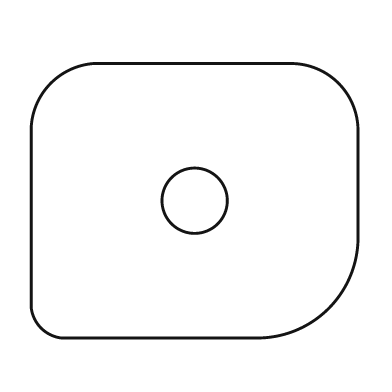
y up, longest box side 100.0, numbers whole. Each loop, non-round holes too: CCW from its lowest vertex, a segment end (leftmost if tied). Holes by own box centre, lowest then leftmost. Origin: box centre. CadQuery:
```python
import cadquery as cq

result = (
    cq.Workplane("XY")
    .moveTo(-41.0, -42.0)
    .lineTo(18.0, -42.0)
    .threePointArc((41.0, -33.0), (50.0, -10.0))
    .lineTo(50.0, 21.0)
    .threePointArc((44.0, 36.0), (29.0, 42.0))
    .lineTo(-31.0, 42.0)
    .threePointArc((-44.0, 36.0), (-50.0, 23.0))
    .lineTo(-50.0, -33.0)
    .threePointArc((-47.0, -39.0), (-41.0, -42.0))
    .close()
    .moveTo(0.0, 0.0)
    .circle(10.0)
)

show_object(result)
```